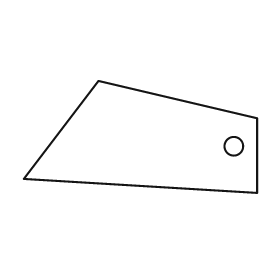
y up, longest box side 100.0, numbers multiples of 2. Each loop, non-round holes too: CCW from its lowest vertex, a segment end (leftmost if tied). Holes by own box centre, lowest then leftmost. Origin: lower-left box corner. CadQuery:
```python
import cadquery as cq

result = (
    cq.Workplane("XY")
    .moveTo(100.0, 0.0)
    .lineTo(100.0, 32.0)
    .lineTo(32.0, 48.0)
    .lineTo(0.0, 6.0)
    .close()
    .moveTo(90.0, 20.0)
    .circle(4.0)
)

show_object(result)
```